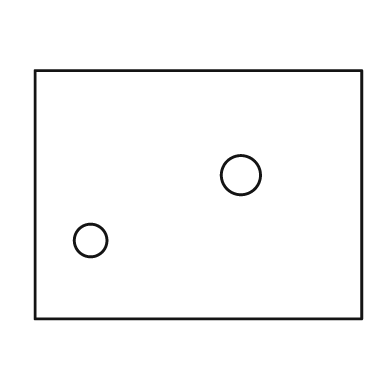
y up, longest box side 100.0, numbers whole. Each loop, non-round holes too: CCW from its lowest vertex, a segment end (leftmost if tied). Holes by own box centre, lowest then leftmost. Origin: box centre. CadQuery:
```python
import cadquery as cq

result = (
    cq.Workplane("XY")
    .moveTo(-50.0, -38.0)
    .lineTo(50.0, -38.0)
    .lineTo(50.0, 38.0)
    .lineTo(-50.0, 38.0)
    .close()
    .moveTo(-33.0, -14.0)
    .circle(5.0)
    .moveTo(13.0, 6.0)
    .circle(6.0)
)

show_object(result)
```